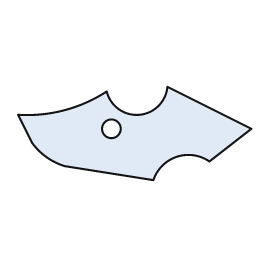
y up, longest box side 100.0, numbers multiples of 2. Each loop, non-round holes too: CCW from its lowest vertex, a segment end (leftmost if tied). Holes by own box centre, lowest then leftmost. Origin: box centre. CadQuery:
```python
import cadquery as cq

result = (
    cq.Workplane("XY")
    .moveTo(8.0, -20.0)
    .threePointArc((18.0, -10.0), (32.0, -12.0))
    .lineTo(50.0, 2.0)
    .lineTo(14.0, 20.0)
    .threePointArc((2.0, 8.0), (-12.0, 18.0))
    .threePointArc((-30.0, 10.0), (-50.0, 8.0))
    .lineTo(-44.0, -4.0)
    .threePointArc((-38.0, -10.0), (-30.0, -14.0))
    .close()
    .moveTo(-10.0, 2.0)
    .circle(4.0)
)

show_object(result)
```